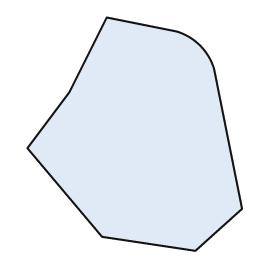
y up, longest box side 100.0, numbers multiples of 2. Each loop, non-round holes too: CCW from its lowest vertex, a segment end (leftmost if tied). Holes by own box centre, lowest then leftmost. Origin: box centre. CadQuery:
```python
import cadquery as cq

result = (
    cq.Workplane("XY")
    .moveTo(26.0, -50.0)
    .lineTo(46.0, -32.0)
    .lineTo(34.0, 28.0)
    .threePointArc((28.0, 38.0), (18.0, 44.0))
    .lineTo(-12.0, 50.0)
    .lineTo(-28.0, 18.0)
    .lineTo(-46.0, -6.0)
    .lineTo(-14.0, -44.0)
    .close()
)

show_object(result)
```